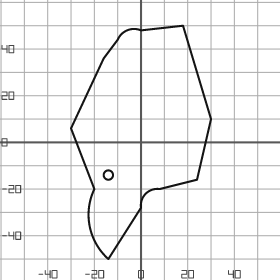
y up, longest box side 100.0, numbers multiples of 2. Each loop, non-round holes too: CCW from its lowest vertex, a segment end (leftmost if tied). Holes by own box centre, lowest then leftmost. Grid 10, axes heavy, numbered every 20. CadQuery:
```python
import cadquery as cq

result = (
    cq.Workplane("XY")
    .moveTo(-14.0, -50.0)
    .lineTo(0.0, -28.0)
    .threePointArc((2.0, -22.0), (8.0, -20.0))
    .lineTo(24.0, -16.0)
    .lineTo(30.0, 10.0)
    .lineTo(18.0, 50.0)
    .lineTo(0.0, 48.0)
    .threePointArc((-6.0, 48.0), (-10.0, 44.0))
    .lineTo(-16.0, 36.0)
    .lineTo(-30.0, 6.0)
    .lineTo(-20.0, -20.0)
    .threePointArc((-22.0, -36.0), (-14.0, -50.0))
    .close()
    .moveTo(-14.0, -14.0)
    .circle(2.0)
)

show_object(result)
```